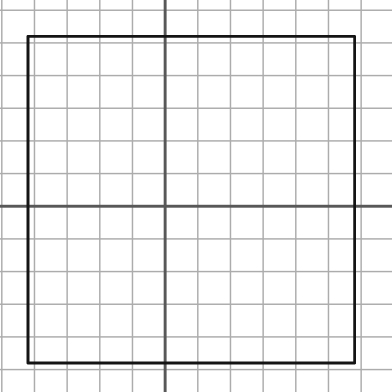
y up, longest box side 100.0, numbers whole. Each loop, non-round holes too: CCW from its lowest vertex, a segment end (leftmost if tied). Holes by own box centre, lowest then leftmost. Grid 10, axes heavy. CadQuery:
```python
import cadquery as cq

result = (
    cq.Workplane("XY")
    .moveTo(-42.0, -48.0)
    .lineTo(58.0, -48.0)
    .lineTo(58.0, 52.0)
    .lineTo(-42.0, 52.0)
    .close()
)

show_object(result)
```